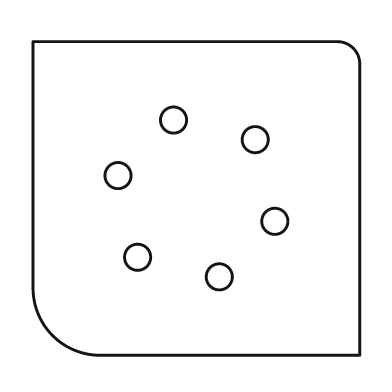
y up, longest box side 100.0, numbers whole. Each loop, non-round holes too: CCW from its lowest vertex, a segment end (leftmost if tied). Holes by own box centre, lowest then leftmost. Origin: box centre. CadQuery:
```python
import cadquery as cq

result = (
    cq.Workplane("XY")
    .moveTo(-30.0, -48.0)
    .lineTo(50.0, -48.0)
    .lineTo(50.0, 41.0)
    .threePointArc((48.0, 46.0), (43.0, 48.0))
    .lineTo(-50.0, 48.0)
    .lineTo(-50.0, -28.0)
    .threePointArc((-44.0, -42.0), (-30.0, -48.0))
    .close()
    .moveTo(7.0, -24.0)
    .circle(4.0)
    .moveTo(-18.0, -18.0)
    .circle(4.0)
    .moveTo(24.0, -7.0)
    .circle(4.0)
    .moveTo(-24.0, 7.0)
    .circle(4.0)
    .moveTo(18.0, 18.0)
    .circle(4.0)
    .moveTo(-7.0, 24.0)
    .circle(4.0)
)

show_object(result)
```